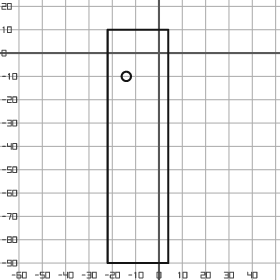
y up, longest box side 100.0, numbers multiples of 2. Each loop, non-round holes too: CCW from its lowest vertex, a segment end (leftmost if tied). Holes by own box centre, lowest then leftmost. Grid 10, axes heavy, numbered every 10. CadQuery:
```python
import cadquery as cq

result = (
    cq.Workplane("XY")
    .moveTo(-22.0, -90.0)
    .lineTo(4.0, -90.0)
    .lineTo(4.0, 10.0)
    .lineTo(-22.0, 10.0)
    .close()
    .moveTo(-14.0, -10.0)
    .circle(2.0)
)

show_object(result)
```